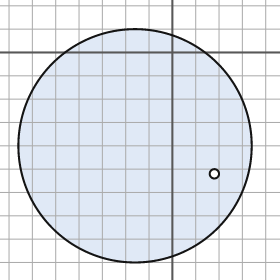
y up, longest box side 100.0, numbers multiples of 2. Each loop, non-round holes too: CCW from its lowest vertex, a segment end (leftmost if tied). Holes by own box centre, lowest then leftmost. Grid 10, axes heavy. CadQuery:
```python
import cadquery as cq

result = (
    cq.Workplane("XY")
    .moveTo(-16.0, -40.0)
    .circle(50.0)
    .moveTo(18.0, -52.0)
    .circle(2.0)
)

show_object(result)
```